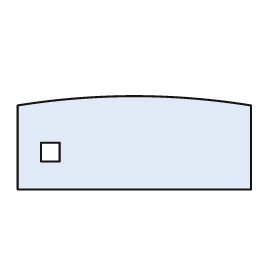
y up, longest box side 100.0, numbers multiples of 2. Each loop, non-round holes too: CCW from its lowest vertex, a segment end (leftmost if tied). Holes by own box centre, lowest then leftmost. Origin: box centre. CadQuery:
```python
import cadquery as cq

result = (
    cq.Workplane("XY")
    .moveTo(-50.0, -20.0)
    .lineTo(50.0, -20.0)
    .lineTo(50.0, 16.0)
    .threePointArc((0.0, 20.0), (-50.0, 16.0))
    .close()
    .moveTo(-40.0, -8.0)
    .lineTo(-32.0, -8.0)
    .lineTo(-32.0, 0.0)
    .lineTo(-40.0, 0.0)
    .close()
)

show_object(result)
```